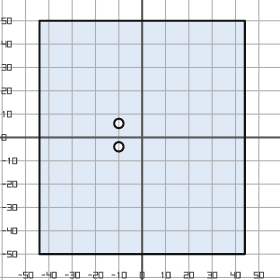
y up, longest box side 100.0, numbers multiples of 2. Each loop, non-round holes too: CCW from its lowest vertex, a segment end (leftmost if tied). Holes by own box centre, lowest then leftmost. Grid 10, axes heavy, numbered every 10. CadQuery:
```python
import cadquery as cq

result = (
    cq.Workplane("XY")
    .moveTo(-44.0, -50.0)
    .lineTo(44.0, -50.0)
    .lineTo(44.0, 50.0)
    .lineTo(-44.0, 50.0)
    .close()
    .moveTo(-10.0, -4.0)
    .circle(2.0)
    .moveTo(-10.0, 6.0)
    .circle(2.0)
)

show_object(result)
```